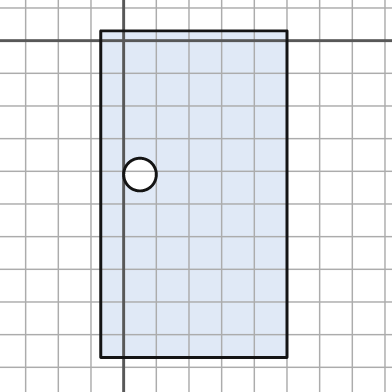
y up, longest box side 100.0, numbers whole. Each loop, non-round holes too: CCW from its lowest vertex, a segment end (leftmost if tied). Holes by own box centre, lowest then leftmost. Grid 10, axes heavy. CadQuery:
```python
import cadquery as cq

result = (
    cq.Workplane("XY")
    .moveTo(-7.0, -97.0)
    .lineTo(50.0, -97.0)
    .lineTo(50.0, 3.0)
    .lineTo(-7.0, 3.0)
    .close()
    .moveTo(5.0, -41.0)
    .circle(5.0)
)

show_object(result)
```